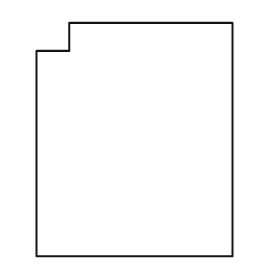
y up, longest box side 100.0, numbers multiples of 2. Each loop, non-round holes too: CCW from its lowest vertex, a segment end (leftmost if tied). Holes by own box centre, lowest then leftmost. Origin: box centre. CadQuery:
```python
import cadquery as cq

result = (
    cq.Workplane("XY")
    .moveTo(-42.0, -50.0)
    .lineTo(42.0, -50.0)
    .lineTo(42.0, 50.0)
    .lineTo(-28.0, 50.0)
    .lineTo(-28.0, 38.0)
    .lineTo(-42.0, 38.0)
    .close()
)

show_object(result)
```